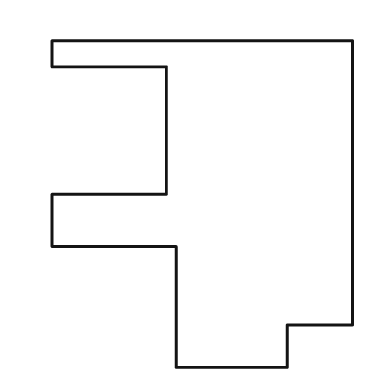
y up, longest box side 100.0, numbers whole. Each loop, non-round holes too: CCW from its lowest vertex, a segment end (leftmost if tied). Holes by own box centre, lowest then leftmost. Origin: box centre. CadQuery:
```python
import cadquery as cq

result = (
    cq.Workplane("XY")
    .moveTo(-8.0, -50.0)
    .lineTo(26.0, -50.0)
    .lineTo(26.0, -37.0)
    .lineTo(46.0, -37.0)
    .lineTo(46.0, 50.0)
    .lineTo(-46.0, 50.0)
    .lineTo(-46.0, 42.0)
    .lineTo(-11.0, 42.0)
    .lineTo(-11.0, 3.0)
    .lineTo(-46.0, 3.0)
    .lineTo(-46.0, -13.0)
    .lineTo(-8.0, -13.0)
    .close()
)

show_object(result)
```